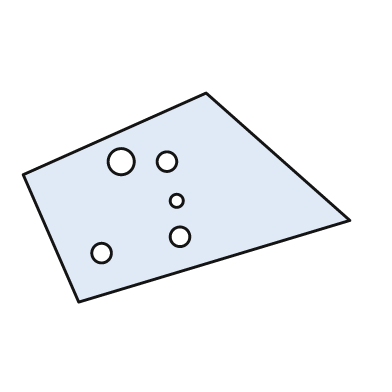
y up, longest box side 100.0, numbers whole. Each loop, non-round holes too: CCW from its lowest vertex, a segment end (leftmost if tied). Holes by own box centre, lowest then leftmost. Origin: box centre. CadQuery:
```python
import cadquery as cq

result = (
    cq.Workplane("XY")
    .moveTo(-33.0, -32.0)
    .lineTo(50.0, -7.0)
    .lineTo(6.0, 32.0)
    .lineTo(-50.0, 7.0)
    .close()
    .moveTo(-26.0, -17.0)
    .circle(3.0)
    .moveTo(-2.0, -12.0)
    .circle(3.0)
    .moveTo(-3.0, -1.0)
    .circle(2.0)
    .moveTo(-20.0, 11.0)
    .circle(4.0)
    .moveTo(-6.0, 11.0)
    .circle(3.0)
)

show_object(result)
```